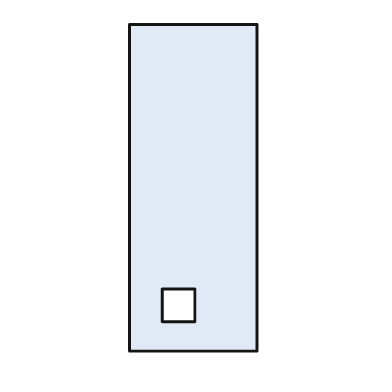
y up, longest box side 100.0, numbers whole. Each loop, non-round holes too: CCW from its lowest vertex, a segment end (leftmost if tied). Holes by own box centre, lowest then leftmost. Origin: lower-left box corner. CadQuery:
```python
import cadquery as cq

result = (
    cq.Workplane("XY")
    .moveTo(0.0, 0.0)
    .lineTo(39.0, 0.0)
    .lineTo(39.0, 100.0)
    .lineTo(0.0, 100.0)
    .close()
    .moveTo(10.0, 9.0)
    .lineTo(20.0, 9.0)
    .lineTo(20.0, 19.0)
    .lineTo(10.0, 19.0)
    .close()
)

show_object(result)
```